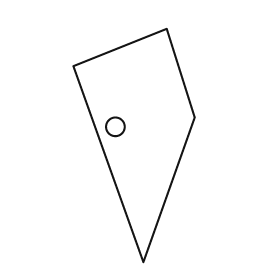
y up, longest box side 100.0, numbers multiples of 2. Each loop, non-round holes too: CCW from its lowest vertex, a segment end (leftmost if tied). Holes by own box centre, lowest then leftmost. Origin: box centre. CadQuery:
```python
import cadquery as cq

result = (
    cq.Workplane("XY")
    .moveTo(4.0, -50.0)
    .lineTo(26.0, 12.0)
    .lineTo(14.0, 50.0)
    .lineTo(-26.0, 34.0)
    .close()
    .moveTo(-8.0, 8.0)
    .circle(4.0)
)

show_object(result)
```